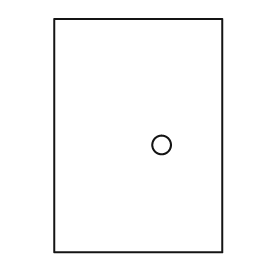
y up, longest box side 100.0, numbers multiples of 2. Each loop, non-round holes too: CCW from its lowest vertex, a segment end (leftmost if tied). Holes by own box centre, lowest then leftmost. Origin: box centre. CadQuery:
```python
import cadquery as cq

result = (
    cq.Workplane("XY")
    .moveTo(-36.0, -50.0)
    .lineTo(36.0, -50.0)
    .lineTo(36.0, 50.0)
    .lineTo(-36.0, 50.0)
    .close()
    .moveTo(10.0, -4.0)
    .circle(4.0)
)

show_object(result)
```